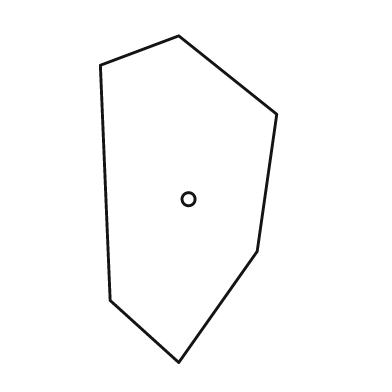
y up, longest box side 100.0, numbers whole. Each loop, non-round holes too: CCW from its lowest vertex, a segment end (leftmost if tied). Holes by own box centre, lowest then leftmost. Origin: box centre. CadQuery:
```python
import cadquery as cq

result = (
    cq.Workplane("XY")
    .moveTo(-3.0, -50.0)
    .lineTo(21.0, -16.0)
    .lineTo(27.0, 26.0)
    .lineTo(-3.0, 50.0)
    .lineTo(-27.0, 41.0)
    .lineTo(-24.0, -31.0)
    .close()
    .moveTo(0.0, 0.0)
    .circle(2.0)
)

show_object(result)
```